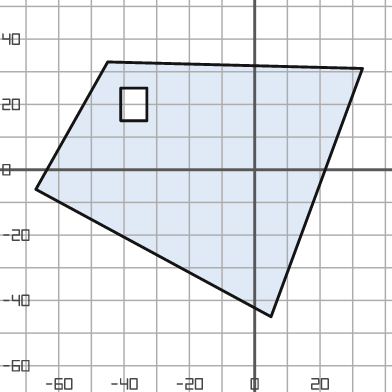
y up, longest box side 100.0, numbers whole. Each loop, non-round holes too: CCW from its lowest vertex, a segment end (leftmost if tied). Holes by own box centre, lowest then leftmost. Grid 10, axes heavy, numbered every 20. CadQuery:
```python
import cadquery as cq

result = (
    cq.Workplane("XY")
    .moveTo(5.0, -45.0)
    .lineTo(33.0, 31.0)
    .lineTo(-45.0, 33.0)
    .lineTo(-67.0, -6.0)
    .close()
    .moveTo(-41.0, 15.0)
    .lineTo(-33.0, 15.0)
    .lineTo(-33.0, 25.0)
    .lineTo(-41.0, 25.0)
    .close()
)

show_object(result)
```